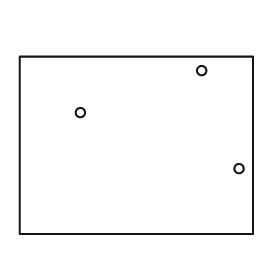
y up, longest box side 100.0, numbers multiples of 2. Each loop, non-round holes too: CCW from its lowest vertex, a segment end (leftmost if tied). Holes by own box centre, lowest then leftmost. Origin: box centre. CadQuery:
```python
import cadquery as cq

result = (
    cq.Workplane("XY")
    .moveTo(-50.0, -38.0)
    .lineTo(50.0, -38.0)
    .lineTo(50.0, 38.0)
    .lineTo(-50.0, 38.0)
    .close()
    .moveTo(44.0, -10.0)
    .circle(2.0)
    .moveTo(-24.0, 14.0)
    .circle(2.0)
    .moveTo(28.0, 32.0)
    .circle(2.0)
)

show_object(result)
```